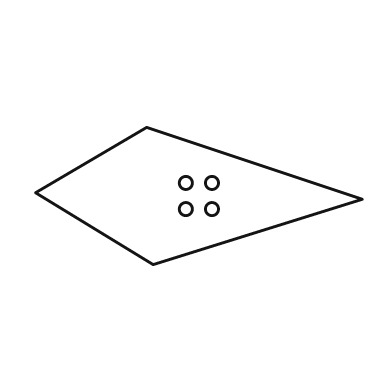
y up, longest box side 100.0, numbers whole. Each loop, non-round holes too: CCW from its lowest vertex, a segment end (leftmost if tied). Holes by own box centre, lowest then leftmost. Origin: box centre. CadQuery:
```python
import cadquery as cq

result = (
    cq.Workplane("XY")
    .moveTo(-14.0, -21.0)
    .lineTo(50.0, -1.0)
    .lineTo(-16.0, 21.0)
    .lineTo(-50.0, 1.0)
    .close()
    .moveTo(-4.0, -4.0)
    .circle(2.0)
    .moveTo(4.0, -4.0)
    .circle(2.0)
    .moveTo(-4.0, 4.0)
    .circle(2.0)
    .moveTo(4.0, 4.0)
    .circle(2.0)
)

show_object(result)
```